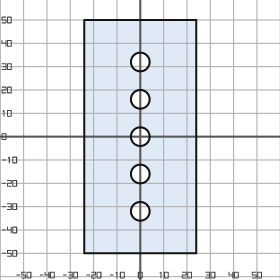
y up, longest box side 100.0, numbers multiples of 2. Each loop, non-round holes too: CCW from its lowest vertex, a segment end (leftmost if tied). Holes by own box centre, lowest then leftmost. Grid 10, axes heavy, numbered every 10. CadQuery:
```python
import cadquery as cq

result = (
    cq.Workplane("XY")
    .moveTo(-24.0, -50.0)
    .lineTo(24.0, -50.0)
    .lineTo(24.0, 50.0)
    .lineTo(-24.0, 50.0)
    .close()
    .moveTo(0.0, -32.0)
    .circle(4.0)
    .moveTo(0.0, -16.0)
    .circle(4.0)
    .moveTo(0.0, 0.0)
    .circle(4.0)
    .moveTo(0.0, 16.0)
    .circle(4.0)
    .moveTo(0.0, 32.0)
    .circle(4.0)
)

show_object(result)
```